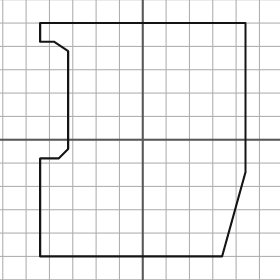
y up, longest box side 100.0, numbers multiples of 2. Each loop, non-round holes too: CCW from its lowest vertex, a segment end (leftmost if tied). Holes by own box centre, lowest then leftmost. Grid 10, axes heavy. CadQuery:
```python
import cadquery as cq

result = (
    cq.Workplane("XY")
    .moveTo(-44.0, -50.0)
    .lineTo(34.0, -50.0)
    .lineTo(44.0, -14.0)
    .lineTo(44.0, 50.0)
    .lineTo(-44.0, 50.0)
    .lineTo(-44.0, 42.0)
    .lineTo(-38.0, 42.0)
    .lineTo(-32.0, 38.0)
    .lineTo(-32.0, -4.0)
    .lineTo(-36.0, -8.0)
    .lineTo(-44.0, -8.0)
    .close()
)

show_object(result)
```